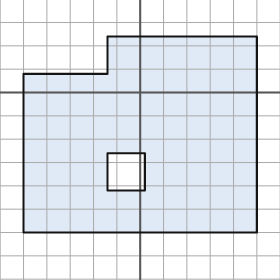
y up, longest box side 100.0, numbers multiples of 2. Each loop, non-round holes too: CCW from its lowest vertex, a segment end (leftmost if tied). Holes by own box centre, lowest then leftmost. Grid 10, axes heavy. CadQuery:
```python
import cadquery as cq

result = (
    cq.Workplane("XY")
    .moveTo(-50.0, -60.0)
    .lineTo(50.0, -60.0)
    .lineTo(50.0, 24.0)
    .lineTo(-14.0, 24.0)
    .lineTo(-14.0, 8.0)
    .lineTo(-50.0, 8.0)
    .close()
    .moveTo(-14.0, -42.0)
    .lineTo(2.0, -42.0)
    .lineTo(2.0, -26.0)
    .lineTo(-14.0, -26.0)
    .close()
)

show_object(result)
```